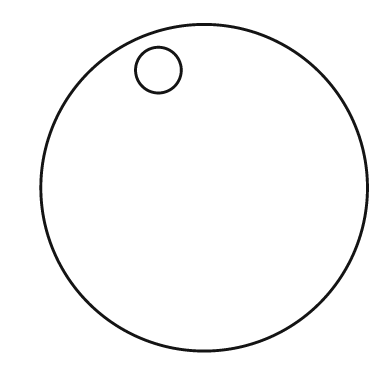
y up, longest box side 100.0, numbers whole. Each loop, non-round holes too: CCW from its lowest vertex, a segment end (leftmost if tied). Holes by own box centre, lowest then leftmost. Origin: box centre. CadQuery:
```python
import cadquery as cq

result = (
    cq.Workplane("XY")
    .moveTo(0.0, 0.0)
    .circle(50.0)
    .moveTo(-14.0, 36.0)
    .circle(7.0)
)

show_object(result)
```